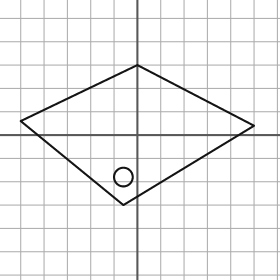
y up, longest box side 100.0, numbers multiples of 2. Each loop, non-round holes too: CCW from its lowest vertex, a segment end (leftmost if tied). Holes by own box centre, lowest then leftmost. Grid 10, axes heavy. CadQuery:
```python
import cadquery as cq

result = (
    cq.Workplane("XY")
    .moveTo(-6.0, -30.0)
    .lineTo(50.0, 4.0)
    .lineTo(0.0, 30.0)
    .lineTo(-50.0, 6.0)
    .close()
    .moveTo(-6.0, -18.0)
    .circle(4.0)
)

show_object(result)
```